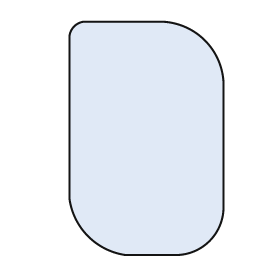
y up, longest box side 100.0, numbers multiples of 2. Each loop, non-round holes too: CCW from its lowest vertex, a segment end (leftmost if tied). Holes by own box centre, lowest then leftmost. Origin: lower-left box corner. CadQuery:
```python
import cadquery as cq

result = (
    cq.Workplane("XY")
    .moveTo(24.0, 0.0)
    .lineTo(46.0, 0.0)
    .threePointArc((60.0, 6.0), (66.0, 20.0))
    .lineTo(66.0, 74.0)
    .threePointArc((58.0, 92.0), (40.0, 100.0))
    .lineTo(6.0, 100.0)
    .threePointArc((2.0, 98.0), (0.0, 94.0))
    .lineTo(0.0, 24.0)
    .threePointArc((8.0, 8.0), (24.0, 0.0))
    .close()
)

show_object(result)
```